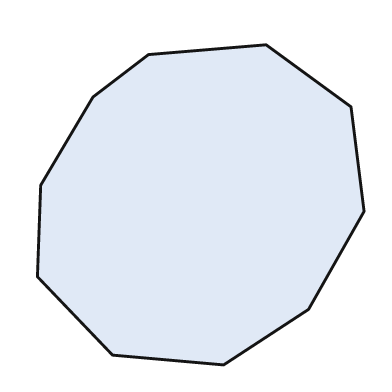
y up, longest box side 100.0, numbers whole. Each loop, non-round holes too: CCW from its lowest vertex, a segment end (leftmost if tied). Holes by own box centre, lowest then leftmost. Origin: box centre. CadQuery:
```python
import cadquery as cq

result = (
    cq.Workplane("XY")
    .moveTo(7.0, -49.0)
    .lineTo(33.0, -32.0)
    .lineTo(50.0, -2.0)
    .lineTo(46.0, 30.0)
    .lineTo(20.0, 49.0)
    .lineTo(-16.0, 46.0)
    .lineTo(-33.0, 33.0)
    .lineTo(-49.0, 6.0)
    .lineTo(-50.0, -22.0)
    .lineTo(-27.0, -46.0)
    .close()
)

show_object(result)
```